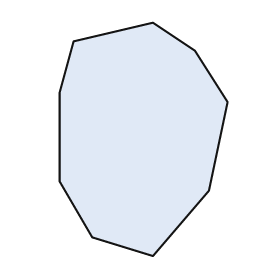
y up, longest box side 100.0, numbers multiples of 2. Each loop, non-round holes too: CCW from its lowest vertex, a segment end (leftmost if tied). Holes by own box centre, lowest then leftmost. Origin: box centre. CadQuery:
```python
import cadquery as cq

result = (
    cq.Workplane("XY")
    .moveTo(4.0, -50.0)
    .lineTo(28.0, -22.0)
    .lineTo(36.0, 16.0)
    .lineTo(22.0, 38.0)
    .lineTo(4.0, 50.0)
    .lineTo(-30.0, 42.0)
    .lineTo(-36.0, 20.0)
    .lineTo(-36.0, -18.0)
    .lineTo(-22.0, -42.0)
    .close()
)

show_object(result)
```